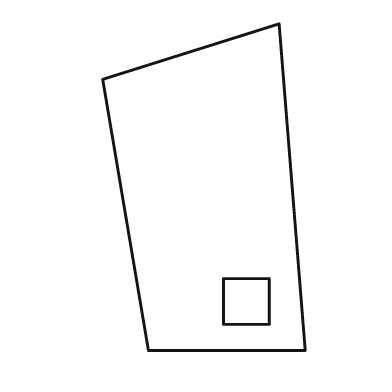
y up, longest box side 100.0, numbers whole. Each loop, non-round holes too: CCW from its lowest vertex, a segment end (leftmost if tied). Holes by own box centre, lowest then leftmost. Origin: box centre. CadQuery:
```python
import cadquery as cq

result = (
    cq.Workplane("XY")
    .moveTo(-17.0, -50.0)
    .lineTo(31.0, -50.0)
    .lineTo(23.0, 50.0)
    .lineTo(-31.0, 33.0)
    .close()
    .moveTo(6.0, -42.0)
    .lineTo(20.0, -42.0)
    .lineTo(20.0, -28.0)
    .lineTo(6.0, -28.0)
    .close()
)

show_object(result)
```